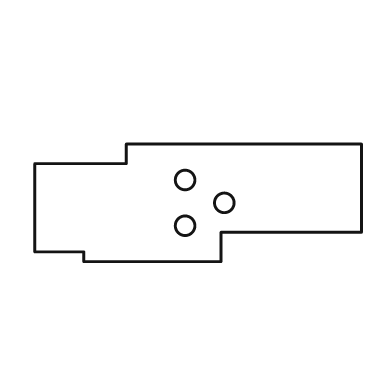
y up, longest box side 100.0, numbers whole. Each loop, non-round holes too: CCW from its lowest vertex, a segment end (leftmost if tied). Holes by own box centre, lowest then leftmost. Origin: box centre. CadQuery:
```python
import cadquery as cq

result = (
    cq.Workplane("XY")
    .moveTo(-35.0, -18.0)
    .lineTo(7.0, -18.0)
    .lineTo(7.0, -9.0)
    .lineTo(50.0, -9.0)
    .lineTo(50.0, 18.0)
    .lineTo(-22.0, 18.0)
    .lineTo(-22.0, 12.0)
    .lineTo(-50.0, 12.0)
    .lineTo(-50.0, -15.0)
    .lineTo(-35.0, -15.0)
    .close()
    .moveTo(-4.0, -7.0)
    .circle(3.0)
    .moveTo(8.0, 0.0)
    .circle(3.0)
    .moveTo(-4.0, 7.0)
    .circle(3.0)
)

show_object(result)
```